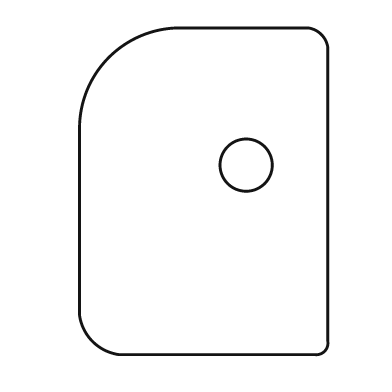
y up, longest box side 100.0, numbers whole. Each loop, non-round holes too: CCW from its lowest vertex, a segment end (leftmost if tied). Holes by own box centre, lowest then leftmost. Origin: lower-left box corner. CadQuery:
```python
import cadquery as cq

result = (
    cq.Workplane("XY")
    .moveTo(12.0, 0.0)
    .lineTo(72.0, 0.0)
    .threePointArc((75.0, 1.0), (76.0, 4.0))
    .lineTo(76.0, 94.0)
    .threePointArc((74.0, 98.0), (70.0, 100.0))
    .lineTo(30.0, 100.0)
    .threePointArc((9.0, 91.0), (0.0, 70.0))
    .lineTo(0.0, 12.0)
    .threePointArc((4.0, 4.0), (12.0, 0.0))
    .close()
    .moveTo(51.0, 58.0)
    .circle(8.0)
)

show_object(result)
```